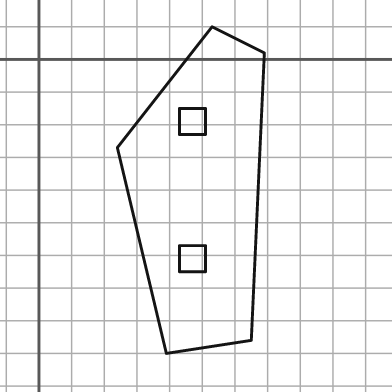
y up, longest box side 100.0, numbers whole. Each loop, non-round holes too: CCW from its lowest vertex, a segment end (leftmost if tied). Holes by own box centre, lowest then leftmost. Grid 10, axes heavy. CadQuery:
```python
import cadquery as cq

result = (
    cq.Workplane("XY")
    .moveTo(39.0, -90.0)
    .lineTo(65.0, -86.0)
    .lineTo(69.0, 2.0)
    .lineTo(53.0, 10.0)
    .lineTo(24.0, -27.0)
    .close()
    .moveTo(43.0, -65.0)
    .lineTo(51.0, -65.0)
    .lineTo(51.0, -57.0)
    .lineTo(43.0, -57.0)
    .close()
    .moveTo(43.0, -23.0)
    .lineTo(51.0, -23.0)
    .lineTo(51.0, -15.0)
    .lineTo(43.0, -15.0)
    .close()
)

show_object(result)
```